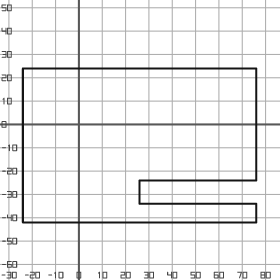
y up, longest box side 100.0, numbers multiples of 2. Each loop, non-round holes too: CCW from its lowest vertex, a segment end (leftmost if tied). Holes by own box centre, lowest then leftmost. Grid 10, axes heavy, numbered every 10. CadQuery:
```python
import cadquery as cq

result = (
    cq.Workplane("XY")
    .moveTo(-24.0, -42.0)
    .lineTo(76.0, -42.0)
    .lineTo(76.0, -34.0)
    .lineTo(26.0, -34.0)
    .lineTo(26.0, -24.0)
    .lineTo(76.0, -24.0)
    .lineTo(76.0, 24.0)
    .lineTo(-24.0, 24.0)
    .close()
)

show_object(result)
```